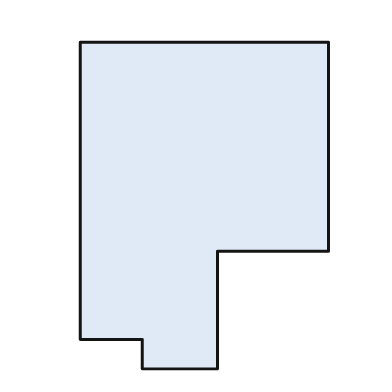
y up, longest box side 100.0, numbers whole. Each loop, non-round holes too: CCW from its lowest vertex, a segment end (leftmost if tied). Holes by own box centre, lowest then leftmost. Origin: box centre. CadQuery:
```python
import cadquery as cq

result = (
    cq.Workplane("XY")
    .moveTo(-19.0, -50.0)
    .lineTo(4.0, -50.0)
    .lineTo(4.0, -14.0)
    .lineTo(38.0, -14.0)
    .lineTo(38.0, 50.0)
    .lineTo(-38.0, 50.0)
    .lineTo(-38.0, -41.0)
    .lineTo(-19.0, -41.0)
    .close()
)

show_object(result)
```